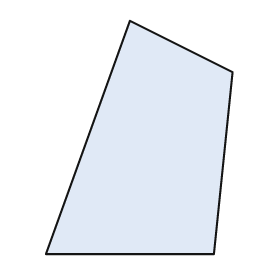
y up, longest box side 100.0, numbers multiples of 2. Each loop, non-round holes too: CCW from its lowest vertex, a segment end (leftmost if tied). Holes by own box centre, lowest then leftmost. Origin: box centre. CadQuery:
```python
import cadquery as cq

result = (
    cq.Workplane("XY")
    .moveTo(-40.0, -50.0)
    .lineTo(32.0, -50.0)
    .lineTo(40.0, 28.0)
    .lineTo(-4.0, 50.0)
    .close()
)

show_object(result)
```